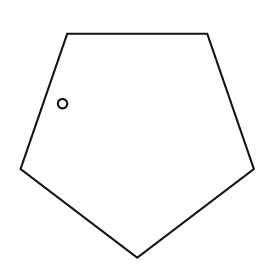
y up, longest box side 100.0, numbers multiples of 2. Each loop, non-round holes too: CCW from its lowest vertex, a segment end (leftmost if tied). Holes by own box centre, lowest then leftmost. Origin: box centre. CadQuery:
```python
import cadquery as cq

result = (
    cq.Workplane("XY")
    .moveTo(0.0, -48.0)
    .lineTo(50.0, -10.0)
    .lineTo(30.0, 48.0)
    .lineTo(-30.0, 48.0)
    .lineTo(-50.0, -10.0)
    .close()
    .moveTo(-32.0, 18.0)
    .circle(2.0)
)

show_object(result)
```